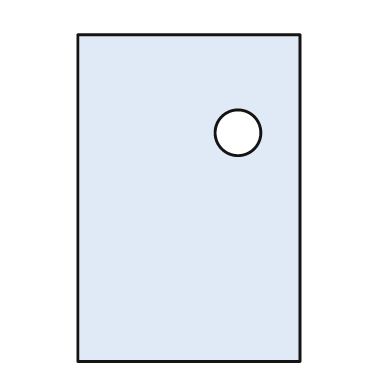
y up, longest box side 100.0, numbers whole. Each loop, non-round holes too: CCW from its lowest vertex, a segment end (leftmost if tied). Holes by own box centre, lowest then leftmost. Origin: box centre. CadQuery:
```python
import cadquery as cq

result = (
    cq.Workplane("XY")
    .moveTo(-34.0, -50.0)
    .lineTo(34.0, -50.0)
    .lineTo(34.0, 50.0)
    .lineTo(-34.0, 50.0)
    .close()
    .moveTo(15.0, 20.0)
    .circle(7.0)
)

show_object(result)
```